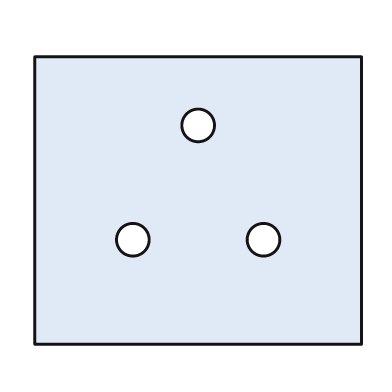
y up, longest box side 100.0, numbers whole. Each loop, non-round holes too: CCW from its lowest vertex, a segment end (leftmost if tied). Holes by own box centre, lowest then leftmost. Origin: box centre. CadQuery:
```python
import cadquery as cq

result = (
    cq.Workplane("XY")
    .moveTo(-50.0, -44.0)
    .lineTo(50.0, -44.0)
    .lineTo(50.0, 44.0)
    .lineTo(-50.0, 44.0)
    .close()
    .moveTo(-20.0, -12.0)
    .circle(5.0)
    .moveTo(20.0, -12.0)
    .circle(5.0)
    .moveTo(0.0, 23.0)
    .circle(5.0)
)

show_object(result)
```